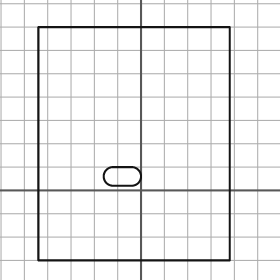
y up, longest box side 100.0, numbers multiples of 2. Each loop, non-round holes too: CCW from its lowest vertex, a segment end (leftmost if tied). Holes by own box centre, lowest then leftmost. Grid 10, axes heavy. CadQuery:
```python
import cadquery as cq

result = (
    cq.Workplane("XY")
    .moveTo(-44.0, -30.0)
    .lineTo(38.0, -30.0)
    .lineTo(38.0, 70.0)
    .lineTo(-44.0, 70.0)
    .close()
    .moveTo(-12.0, 2.0)
    .lineTo(-4.0, 2.0)
    .threePointArc((0.0, 6.0), (-4.0, 10.0))
    .lineTo(-12.0, 10.0)
    .threePointArc((-16.0, 6.0), (-12.0, 2.0))
    .close()
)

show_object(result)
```